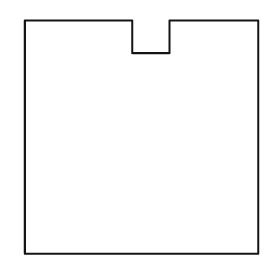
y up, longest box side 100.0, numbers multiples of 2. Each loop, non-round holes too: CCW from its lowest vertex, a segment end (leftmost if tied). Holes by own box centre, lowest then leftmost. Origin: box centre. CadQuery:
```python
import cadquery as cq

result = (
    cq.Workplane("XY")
    .moveTo(-50.0, -50.0)
    .lineTo(50.0, -50.0)
    .lineTo(50.0, 50.0)
    .lineTo(12.0, 50.0)
    .lineTo(12.0, 36.0)
    .lineTo(-4.0, 36.0)
    .lineTo(-4.0, 50.0)
    .lineTo(-50.0, 50.0)
    .close()
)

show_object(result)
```